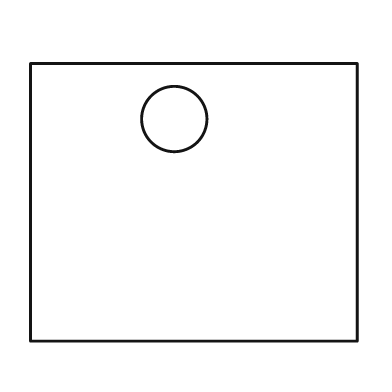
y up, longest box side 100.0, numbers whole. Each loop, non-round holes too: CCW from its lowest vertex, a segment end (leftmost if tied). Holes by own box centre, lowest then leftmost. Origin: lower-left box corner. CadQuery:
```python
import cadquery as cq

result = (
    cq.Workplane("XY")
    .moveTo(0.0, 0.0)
    .lineTo(100.0, 0.0)
    .lineTo(100.0, 85.0)
    .lineTo(0.0, 85.0)
    .close()
    .moveTo(44.0, 68.0)
    .circle(10.0)
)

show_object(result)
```